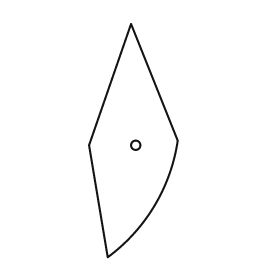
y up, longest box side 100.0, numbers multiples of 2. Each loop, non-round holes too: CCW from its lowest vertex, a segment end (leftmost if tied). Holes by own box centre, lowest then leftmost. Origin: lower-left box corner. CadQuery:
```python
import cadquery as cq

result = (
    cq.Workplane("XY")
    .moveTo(8.0, 0.0)
    .threePointArc((28.0, 22.0), (38.0, 50.0))
    .lineTo(18.0, 100.0)
    .lineTo(0.0, 48.0)
    .close()
    .moveTo(20.0, 48.0)
    .circle(2.0)
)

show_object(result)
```